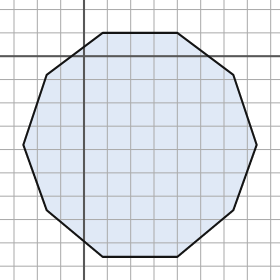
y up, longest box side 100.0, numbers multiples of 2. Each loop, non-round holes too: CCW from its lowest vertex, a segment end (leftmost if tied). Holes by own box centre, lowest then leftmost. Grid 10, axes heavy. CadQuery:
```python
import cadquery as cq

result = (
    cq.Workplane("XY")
    .moveTo(8.0, -86.0)
    .lineTo(40.0, -86.0)
    .lineTo(64.0, -66.0)
    .lineTo(74.0, -38.0)
    .lineTo(64.0, -8.0)
    .lineTo(40.0, 10.0)
    .lineTo(8.0, 10.0)
    .lineTo(-16.0, -8.0)
    .lineTo(-26.0, -38.0)
    .lineTo(-16.0, -66.0)
    .close()
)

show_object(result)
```